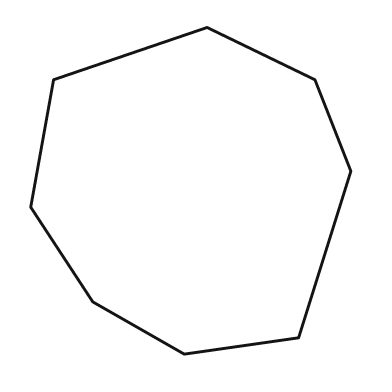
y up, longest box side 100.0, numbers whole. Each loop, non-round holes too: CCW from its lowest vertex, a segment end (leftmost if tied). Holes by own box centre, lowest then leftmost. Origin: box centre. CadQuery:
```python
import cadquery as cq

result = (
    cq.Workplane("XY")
    .moveTo(-2.0, -50.0)
    .lineTo(33.0, -45.0)
    .lineTo(49.0, 6.0)
    .lineTo(38.0, 34.0)
    .lineTo(5.0, 50.0)
    .lineTo(-42.0, 34.0)
    .lineTo(-49.0, -5.0)
    .lineTo(-30.0, -34.0)
    .close()
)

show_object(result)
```